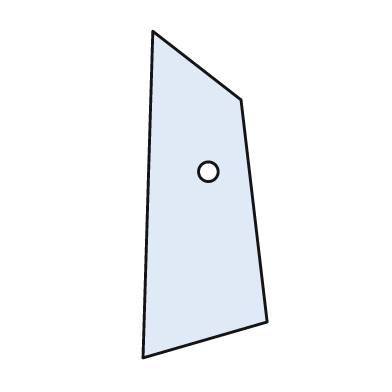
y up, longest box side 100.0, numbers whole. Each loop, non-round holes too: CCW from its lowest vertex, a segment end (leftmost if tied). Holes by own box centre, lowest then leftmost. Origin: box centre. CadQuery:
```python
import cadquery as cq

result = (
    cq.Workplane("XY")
    .moveTo(-19.0, -50.0)
    .lineTo(19.0, -39.0)
    .lineTo(11.0, 29.0)
    .lineTo(-16.0, 50.0)
    .close()
    .moveTo(1.0, 7.0)
    .circle(3.0)
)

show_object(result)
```